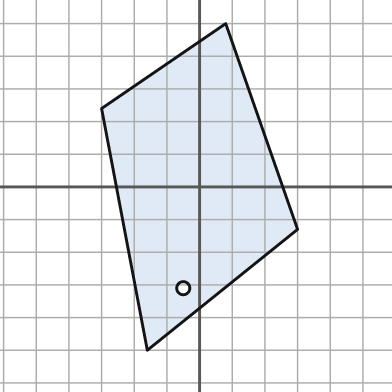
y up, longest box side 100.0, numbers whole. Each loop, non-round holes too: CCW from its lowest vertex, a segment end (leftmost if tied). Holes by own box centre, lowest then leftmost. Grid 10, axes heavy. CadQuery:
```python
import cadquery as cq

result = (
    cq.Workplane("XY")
    .moveTo(-16.0, -50.0)
    .lineTo(30.0, -13.0)
    .lineTo(8.0, 50.0)
    .lineTo(-30.0, 24.0)
    .close()
    .moveTo(-5.0, -31.0)
    .circle(2.0)
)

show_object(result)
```